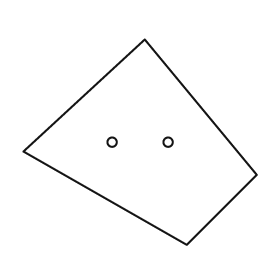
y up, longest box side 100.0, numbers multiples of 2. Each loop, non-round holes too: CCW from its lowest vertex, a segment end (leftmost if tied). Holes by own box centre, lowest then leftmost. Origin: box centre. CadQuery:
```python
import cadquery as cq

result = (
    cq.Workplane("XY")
    .moveTo(20.0, -44.0)
    .lineTo(50.0, -14.0)
    .lineTo(2.0, 44.0)
    .lineTo(-50.0, -4.0)
    .close()
    .moveTo(-12.0, 0.0)
    .circle(2.0)
    .moveTo(12.0, 0.0)
    .circle(2.0)
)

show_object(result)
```